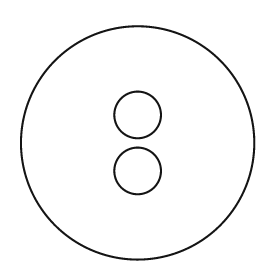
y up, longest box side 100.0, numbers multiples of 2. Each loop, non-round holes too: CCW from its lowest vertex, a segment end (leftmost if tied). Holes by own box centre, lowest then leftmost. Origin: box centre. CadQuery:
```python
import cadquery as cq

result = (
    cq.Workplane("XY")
    .moveTo(0.0, 0.0)
    .circle(50.0)
    .moveTo(0.0, -12.0)
    .circle(10.0)
    .moveTo(0.0, 12.0)
    .circle(10.0)
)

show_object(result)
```